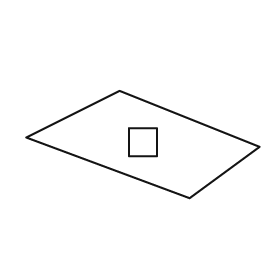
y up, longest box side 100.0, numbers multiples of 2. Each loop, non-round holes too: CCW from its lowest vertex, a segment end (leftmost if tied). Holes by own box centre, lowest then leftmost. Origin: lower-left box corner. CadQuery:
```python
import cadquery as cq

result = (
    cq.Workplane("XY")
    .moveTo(70.0, 0.0)
    .lineTo(100.0, 22.0)
    .lineTo(40.0, 46.0)
    .lineTo(0.0, 26.0)
    .close()
    .moveTo(44.0, 18.0)
    .lineTo(56.0, 18.0)
    .lineTo(56.0, 30.0)
    .lineTo(44.0, 30.0)
    .close()
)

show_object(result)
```